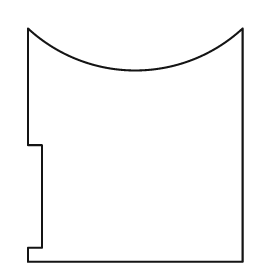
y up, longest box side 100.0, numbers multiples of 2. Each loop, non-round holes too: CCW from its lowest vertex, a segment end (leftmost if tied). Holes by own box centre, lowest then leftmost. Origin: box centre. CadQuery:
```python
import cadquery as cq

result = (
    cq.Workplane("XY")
    .moveTo(-46.0, -50.0)
    .lineTo(46.0, -50.0)
    .lineTo(46.0, 50.0)
    .threePointArc((0.0, 32.0), (-46.0, 50.0))
    .lineTo(-46.0, 0.0)
    .lineTo(-40.0, 0.0)
    .lineTo(-40.0, -44.0)
    .lineTo(-46.0, -44.0)
    .close()
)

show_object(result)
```